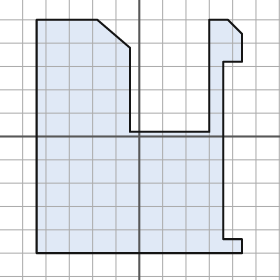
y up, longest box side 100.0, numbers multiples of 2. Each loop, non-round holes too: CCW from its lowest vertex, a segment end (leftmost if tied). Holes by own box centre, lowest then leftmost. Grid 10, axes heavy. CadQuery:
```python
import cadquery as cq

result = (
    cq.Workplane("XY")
    .moveTo(-44.0, -50.0)
    .lineTo(44.0, -50.0)
    .lineTo(44.0, -44.0)
    .lineTo(36.0, -44.0)
    .lineTo(36.0, 32.0)
    .lineTo(44.0, 32.0)
    .lineTo(44.0, 44.0)
    .lineTo(38.0, 50.0)
    .lineTo(30.0, 50.0)
    .lineTo(30.0, 2.0)
    .lineTo(-4.0, 2.0)
    .lineTo(-4.0, 38.0)
    .lineTo(-18.0, 50.0)
    .lineTo(-44.0, 50.0)
    .close()
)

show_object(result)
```